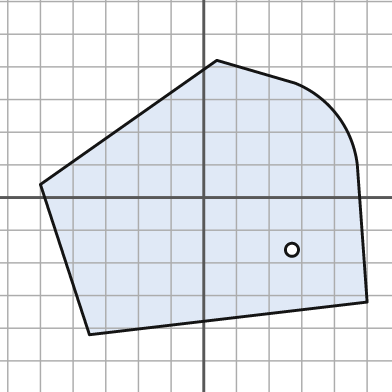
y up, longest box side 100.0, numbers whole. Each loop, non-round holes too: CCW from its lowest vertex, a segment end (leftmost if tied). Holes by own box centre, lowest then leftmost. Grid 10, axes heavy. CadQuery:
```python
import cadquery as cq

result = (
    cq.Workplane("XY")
    .moveTo(-35.0, -42.0)
    .lineTo(50.0, -32.0)
    .lineTo(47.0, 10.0)
    .threePointArc((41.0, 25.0), (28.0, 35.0))
    .lineTo(4.0, 42.0)
    .lineTo(-50.0, 4.0)
    .close()
    .moveTo(27.0, -16.0)
    .circle(2.0)
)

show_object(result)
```